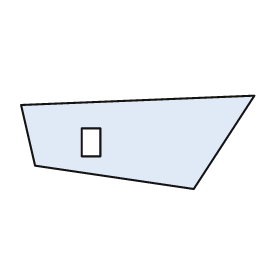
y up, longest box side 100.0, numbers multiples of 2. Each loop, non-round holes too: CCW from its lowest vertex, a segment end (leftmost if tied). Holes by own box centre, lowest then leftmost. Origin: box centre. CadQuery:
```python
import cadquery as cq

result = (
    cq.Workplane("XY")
    .moveTo(24.0, -20.0)
    .lineTo(50.0, 20.0)
    .lineTo(-50.0, 16.0)
    .lineTo(-44.0, -10.0)
    .close()
    .moveTo(-24.0, -6.0)
    .lineTo(-16.0, -6.0)
    .lineTo(-16.0, 6.0)
    .lineTo(-24.0, 6.0)
    .close()
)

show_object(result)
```